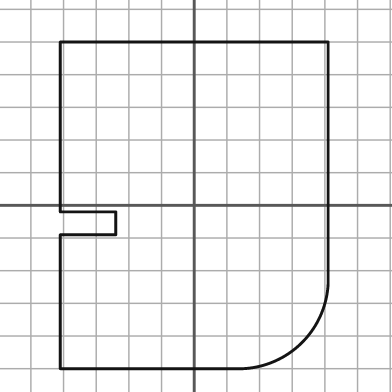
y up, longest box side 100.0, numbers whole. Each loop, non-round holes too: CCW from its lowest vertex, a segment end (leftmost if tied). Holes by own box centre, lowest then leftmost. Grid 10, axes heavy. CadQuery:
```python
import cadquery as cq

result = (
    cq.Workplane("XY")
    .moveTo(-41.0, -50.0)
    .lineTo(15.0, -50.0)
    .threePointArc((33.0, -42.0), (41.0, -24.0))
    .lineTo(41.0, 50.0)
    .lineTo(-41.0, 50.0)
    .lineTo(-41.0, -2.0)
    .lineTo(-24.0, -2.0)
    .lineTo(-24.0, -9.0)
    .lineTo(-41.0, -9.0)
    .close()
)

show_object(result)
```